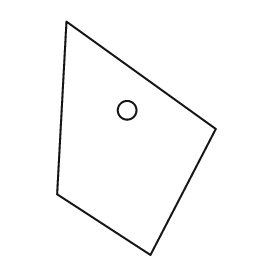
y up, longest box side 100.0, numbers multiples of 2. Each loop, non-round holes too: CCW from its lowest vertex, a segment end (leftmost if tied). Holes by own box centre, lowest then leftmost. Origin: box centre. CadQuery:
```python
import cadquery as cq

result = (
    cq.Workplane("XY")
    .moveTo(6.0, -50.0)
    .lineTo(34.0, 4.0)
    .lineTo(-30.0, 50.0)
    .lineTo(-34.0, -24.0)
    .close()
    .moveTo(-4.0, 12.0)
    .circle(4.0)
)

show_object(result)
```